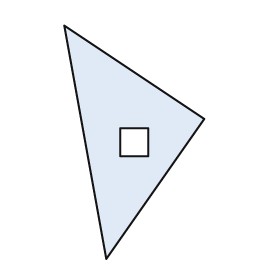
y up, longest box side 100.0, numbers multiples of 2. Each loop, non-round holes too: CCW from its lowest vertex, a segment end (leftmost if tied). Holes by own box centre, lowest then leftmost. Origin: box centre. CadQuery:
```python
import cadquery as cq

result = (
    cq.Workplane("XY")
    .moveTo(-12.0, -50.0)
    .lineTo(30.0, 10.0)
    .lineTo(-30.0, 50.0)
    .close()
    .moveTo(-6.0, -6.0)
    .lineTo(6.0, -6.0)
    .lineTo(6.0, 6.0)
    .lineTo(-6.0, 6.0)
    .close()
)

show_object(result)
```